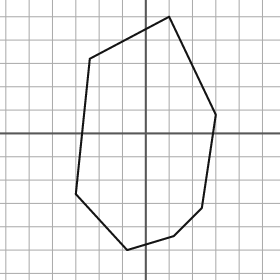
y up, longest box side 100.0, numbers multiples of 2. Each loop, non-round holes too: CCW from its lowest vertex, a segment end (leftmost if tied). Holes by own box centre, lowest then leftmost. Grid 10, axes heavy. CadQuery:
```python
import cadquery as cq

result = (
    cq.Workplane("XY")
    .moveTo(-8.0, -50.0)
    .lineTo(12.0, -44.0)
    .lineTo(24.0, -32.0)
    .lineTo(30.0, 8.0)
    .lineTo(10.0, 50.0)
    .lineTo(-24.0, 32.0)
    .lineTo(-30.0, -26.0)
    .close()
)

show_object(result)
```